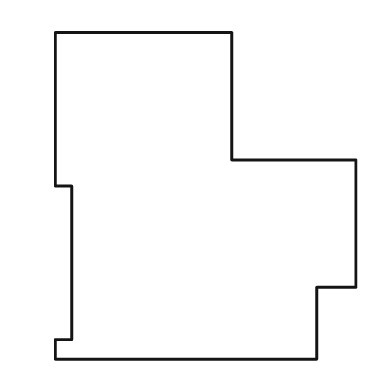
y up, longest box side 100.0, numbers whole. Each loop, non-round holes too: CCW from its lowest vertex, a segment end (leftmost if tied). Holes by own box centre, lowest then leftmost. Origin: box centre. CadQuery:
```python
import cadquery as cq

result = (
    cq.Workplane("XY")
    .moveTo(-46.0, -50.0)
    .lineTo(34.0, -50.0)
    .lineTo(34.0, -28.0)
    .lineTo(46.0, -28.0)
    .lineTo(46.0, 11.0)
    .lineTo(8.0, 11.0)
    .lineTo(8.0, 50.0)
    .lineTo(-46.0, 50.0)
    .lineTo(-46.0, 3.0)
    .lineTo(-41.0, 3.0)
    .lineTo(-41.0, -44.0)
    .lineTo(-46.0, -44.0)
    .close()
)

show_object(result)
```